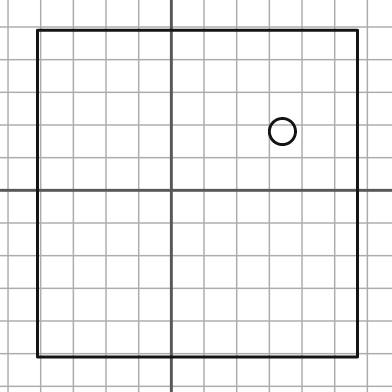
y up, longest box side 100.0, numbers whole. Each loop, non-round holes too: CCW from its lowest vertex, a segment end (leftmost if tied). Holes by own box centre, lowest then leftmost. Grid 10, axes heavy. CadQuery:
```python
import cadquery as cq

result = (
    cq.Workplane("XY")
    .moveTo(-41.0, -51.0)
    .lineTo(57.0, -51.0)
    .lineTo(57.0, 49.0)
    .lineTo(-41.0, 49.0)
    .close()
    .moveTo(34.0, 18.0)
    .circle(4.0)
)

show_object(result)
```